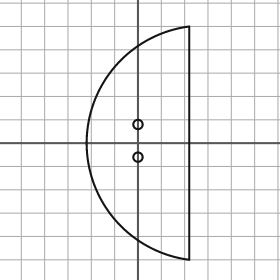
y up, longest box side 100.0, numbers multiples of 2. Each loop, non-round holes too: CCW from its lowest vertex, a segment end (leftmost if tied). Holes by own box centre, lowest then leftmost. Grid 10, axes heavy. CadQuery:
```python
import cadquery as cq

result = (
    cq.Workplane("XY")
    .moveTo(22.0, -50.0)
    .lineTo(22.0, 50.0)
    .threePointArc((-22.0, 0.0), (22.0, -50.0))
    .close()
    .moveTo(0.0, -6.0)
    .circle(2.0)
    .moveTo(0.0, 8.0)
    .circle(2.0)
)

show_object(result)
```